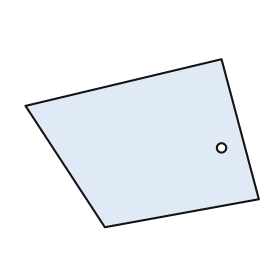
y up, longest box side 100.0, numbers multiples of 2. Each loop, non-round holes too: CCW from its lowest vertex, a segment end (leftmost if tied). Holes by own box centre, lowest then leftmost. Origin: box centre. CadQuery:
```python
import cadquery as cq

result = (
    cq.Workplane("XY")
    .moveTo(-16.0, -36.0)
    .lineTo(50.0, -24.0)
    .lineTo(34.0, 36.0)
    .lineTo(-50.0, 16.0)
    .close()
    .moveTo(34.0, -2.0)
    .circle(2.0)
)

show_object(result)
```